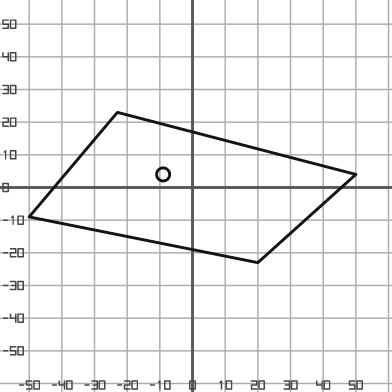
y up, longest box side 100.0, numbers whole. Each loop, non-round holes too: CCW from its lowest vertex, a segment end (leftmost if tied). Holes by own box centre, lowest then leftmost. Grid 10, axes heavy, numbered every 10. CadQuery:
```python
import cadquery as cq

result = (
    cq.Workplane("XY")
    .moveTo(20.0, -23.0)
    .lineTo(50.0, 4.0)
    .lineTo(-23.0, 23.0)
    .lineTo(-50.0, -9.0)
    .close()
    .moveTo(-9.0, 4.0)
    .circle(2.0)
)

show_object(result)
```